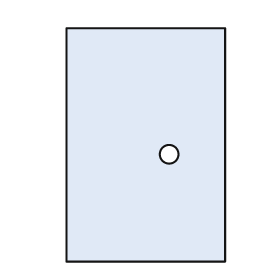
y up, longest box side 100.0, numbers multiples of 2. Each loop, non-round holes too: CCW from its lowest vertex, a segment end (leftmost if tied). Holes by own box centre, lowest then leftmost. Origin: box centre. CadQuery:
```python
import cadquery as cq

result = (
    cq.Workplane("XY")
    .moveTo(-34.0, -50.0)
    .lineTo(34.0, -50.0)
    .lineTo(34.0, 50.0)
    .lineTo(-34.0, 50.0)
    .close()
    .moveTo(10.0, -4.0)
    .circle(4.0)
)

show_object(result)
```